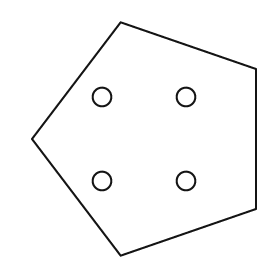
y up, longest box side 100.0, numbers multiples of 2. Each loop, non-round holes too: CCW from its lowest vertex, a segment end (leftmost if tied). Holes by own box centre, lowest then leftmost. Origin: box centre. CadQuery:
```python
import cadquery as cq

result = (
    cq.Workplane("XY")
    .moveTo(-10.0, -50.0)
    .lineTo(48.0, -30.0)
    .lineTo(48.0, 30.0)
    .lineTo(-10.0, 50.0)
    .lineTo(-48.0, 0.0)
    .close()
    .moveTo(-18.0, -18.0)
    .circle(4.0)
    .moveTo(18.0, -18.0)
    .circle(4.0)
    .moveTo(-18.0, 18.0)
    .circle(4.0)
    .moveTo(18.0, 18.0)
    .circle(4.0)
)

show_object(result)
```